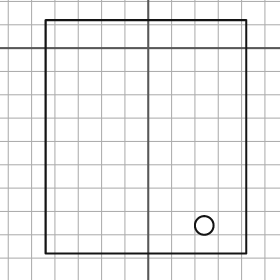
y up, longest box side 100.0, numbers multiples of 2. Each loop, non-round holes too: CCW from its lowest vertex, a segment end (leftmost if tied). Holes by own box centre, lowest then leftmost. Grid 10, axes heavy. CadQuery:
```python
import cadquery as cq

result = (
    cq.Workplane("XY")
    .moveTo(-44.0, -88.0)
    .lineTo(42.0, -88.0)
    .lineTo(42.0, 12.0)
    .lineTo(-44.0, 12.0)
    .close()
    .moveTo(24.0, -76.0)
    .circle(4.0)
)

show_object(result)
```